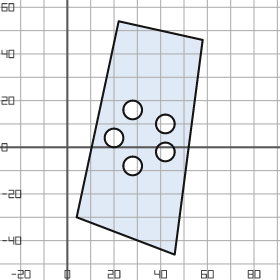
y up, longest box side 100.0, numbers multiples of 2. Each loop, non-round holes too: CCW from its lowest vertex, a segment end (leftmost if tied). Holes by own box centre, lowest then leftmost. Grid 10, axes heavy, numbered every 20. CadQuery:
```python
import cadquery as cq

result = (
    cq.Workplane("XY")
    .moveTo(46.0, -46.0)
    .lineTo(58.0, 46.0)
    .lineTo(22.0, 54.0)
    .lineTo(4.0, -30.0)
    .close()
    .moveTo(28.0, -8.0)
    .circle(4.0)
    .moveTo(42.0, -2.0)
    .circle(4.0)
    .moveTo(20.0, 4.0)
    .circle(4.0)
    .moveTo(42.0, 10.0)
    .circle(4.0)
    .moveTo(28.0, 16.0)
    .circle(4.0)
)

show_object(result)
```